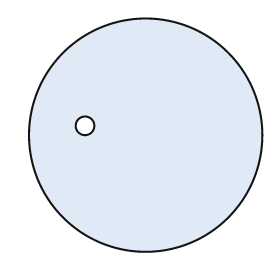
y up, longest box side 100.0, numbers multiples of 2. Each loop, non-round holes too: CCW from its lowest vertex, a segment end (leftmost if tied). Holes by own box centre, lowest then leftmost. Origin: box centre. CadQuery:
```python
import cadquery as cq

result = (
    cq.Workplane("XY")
    .moveTo(0.0, 0.0)
    .circle(50.0)
    .moveTo(-26.0, 4.0)
    .circle(4.0)
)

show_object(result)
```